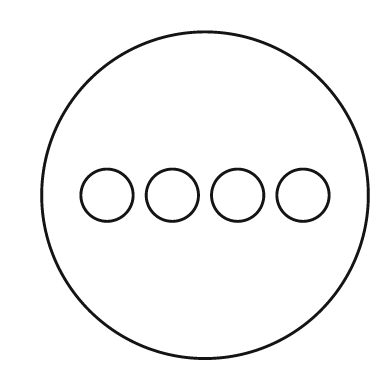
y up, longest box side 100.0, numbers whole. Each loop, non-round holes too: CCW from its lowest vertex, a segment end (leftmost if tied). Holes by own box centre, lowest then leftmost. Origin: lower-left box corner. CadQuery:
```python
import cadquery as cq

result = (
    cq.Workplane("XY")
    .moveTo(50.0, 50.0)
    .circle(50.0)
    .moveTo(20.0, 50.0)
    .circle(8.0)
    .moveTo(40.0, 50.0)
    .circle(8.0)
    .moveTo(60.0, 50.0)
    .circle(8.0)
    .moveTo(80.0, 50.0)
    .circle(8.0)
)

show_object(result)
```